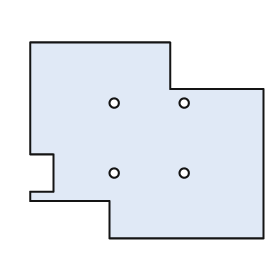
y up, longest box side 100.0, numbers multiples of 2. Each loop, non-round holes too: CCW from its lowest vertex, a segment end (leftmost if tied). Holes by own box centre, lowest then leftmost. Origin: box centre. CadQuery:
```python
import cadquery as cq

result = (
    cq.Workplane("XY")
    .moveTo(-16.0, -42.0)
    .lineTo(50.0, -42.0)
    .lineTo(50.0, 22.0)
    .lineTo(10.0, 22.0)
    .lineTo(10.0, 42.0)
    .lineTo(-50.0, 42.0)
    .lineTo(-50.0, -6.0)
    .lineTo(-40.0, -6.0)
    .lineTo(-40.0, -22.0)
    .lineTo(-50.0, -22.0)
    .lineTo(-50.0, -26.0)
    .lineTo(-16.0, -26.0)
    .close()
    .moveTo(-14.0, -14.0)
    .circle(2.0)
    .moveTo(16.0, -14.0)
    .circle(2.0)
    .moveTo(-14.0, 16.0)
    .circle(2.0)
    .moveTo(16.0, 16.0)
    .circle(2.0)
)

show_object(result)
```